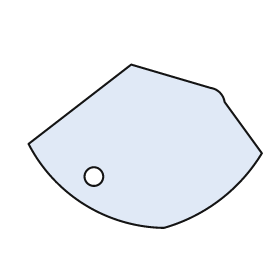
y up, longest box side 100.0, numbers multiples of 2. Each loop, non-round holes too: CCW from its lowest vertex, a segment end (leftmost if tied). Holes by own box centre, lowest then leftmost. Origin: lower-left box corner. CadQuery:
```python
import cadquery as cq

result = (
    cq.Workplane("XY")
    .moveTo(58.0, 0.0)
    .threePointArc((82.0, 12.0), (100.0, 32.0))
    .lineTo(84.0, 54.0)
    .threePointArc((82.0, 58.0), (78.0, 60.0))
    .lineTo(44.0, 70.0)
    .lineTo(0.0, 36.0)
    .threePointArc((24.0, 10.0), (58.0, 0.0))
    .close()
    .moveTo(28.0, 22.0)
    .circle(4.0)
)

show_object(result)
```